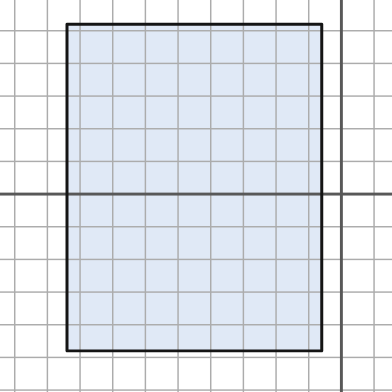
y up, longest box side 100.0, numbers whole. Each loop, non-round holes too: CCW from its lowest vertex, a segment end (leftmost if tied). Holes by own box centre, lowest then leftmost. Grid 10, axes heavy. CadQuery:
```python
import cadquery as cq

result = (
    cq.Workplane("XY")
    .moveTo(-84.0, -48.0)
    .lineTo(-6.0, -48.0)
    .lineTo(-6.0, 52.0)
    .lineTo(-84.0, 52.0)
    .close()
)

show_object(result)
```